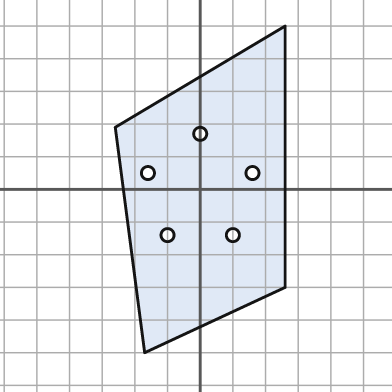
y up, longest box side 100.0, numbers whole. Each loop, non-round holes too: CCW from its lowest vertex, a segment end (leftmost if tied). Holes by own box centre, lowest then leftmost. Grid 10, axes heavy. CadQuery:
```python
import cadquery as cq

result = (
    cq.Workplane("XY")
    .moveTo(-17.0, -50.0)
    .lineTo(26.0, -30.0)
    .lineTo(26.0, 50.0)
    .lineTo(-26.0, 19.0)
    .close()
    .moveTo(-10.0, -14.0)
    .circle(2.0)
    .moveTo(10.0, -14.0)
    .circle(2.0)
    .moveTo(-16.0, 5.0)
    .circle(2.0)
    .moveTo(16.0, 5.0)
    .circle(2.0)
    .moveTo(0.0, 17.0)
    .circle(2.0)
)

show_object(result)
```